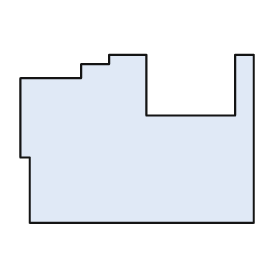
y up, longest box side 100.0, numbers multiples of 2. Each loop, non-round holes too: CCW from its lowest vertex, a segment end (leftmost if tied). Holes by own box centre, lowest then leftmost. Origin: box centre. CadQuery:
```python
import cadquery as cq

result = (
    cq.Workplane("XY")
    .moveTo(-46.0, -36.0)
    .lineTo(50.0, -36.0)
    .lineTo(50.0, 36.0)
    .lineTo(42.0, 36.0)
    .lineTo(42.0, 10.0)
    .lineTo(4.0, 10.0)
    .lineTo(4.0, 36.0)
    .lineTo(-12.0, 36.0)
    .lineTo(-12.0, 32.0)
    .lineTo(-24.0, 32.0)
    .lineTo(-24.0, 26.0)
    .lineTo(-50.0, 26.0)
    .lineTo(-50.0, -8.0)
    .lineTo(-46.0, -8.0)
    .close()
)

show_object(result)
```